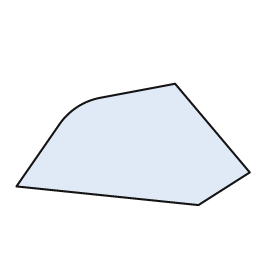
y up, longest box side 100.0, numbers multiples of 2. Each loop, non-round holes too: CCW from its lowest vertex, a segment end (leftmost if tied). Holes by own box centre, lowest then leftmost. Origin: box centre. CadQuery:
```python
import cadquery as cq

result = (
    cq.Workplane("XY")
    .moveTo(28.0, -26.0)
    .lineTo(50.0, -12.0)
    .lineTo(18.0, 26.0)
    .lineTo(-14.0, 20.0)
    .threePointArc((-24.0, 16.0), (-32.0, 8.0))
    .lineTo(-50.0, -18.0)
    .close()
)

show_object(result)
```